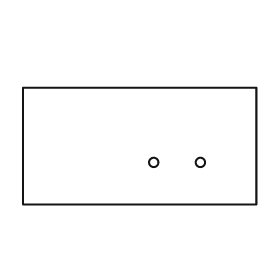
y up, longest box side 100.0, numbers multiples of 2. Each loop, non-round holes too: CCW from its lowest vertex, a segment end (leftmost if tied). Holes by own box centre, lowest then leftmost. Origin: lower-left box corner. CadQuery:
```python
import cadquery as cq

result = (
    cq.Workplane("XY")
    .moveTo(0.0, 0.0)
    .lineTo(100.0, 0.0)
    .lineTo(100.0, 50.0)
    .lineTo(0.0, 50.0)
    .close()
    .moveTo(56.0, 18.0)
    .circle(2.0)
    .moveTo(76.0, 18.0)
    .circle(2.0)
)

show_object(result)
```